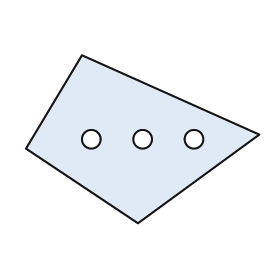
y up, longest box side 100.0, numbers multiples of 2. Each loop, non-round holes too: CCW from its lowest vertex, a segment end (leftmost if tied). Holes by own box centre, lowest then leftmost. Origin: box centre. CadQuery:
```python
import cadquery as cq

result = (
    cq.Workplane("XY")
    .moveTo(-2.0, -36.0)
    .lineTo(50.0, 2.0)
    .lineTo(-26.0, 36.0)
    .lineTo(-50.0, -4.0)
    .close()
    .moveTo(-22.0, 0.0)
    .circle(4.0)
    .moveTo(0.0, 0.0)
    .circle(4.0)
    .moveTo(22.0, 0.0)
    .circle(4.0)
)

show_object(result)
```